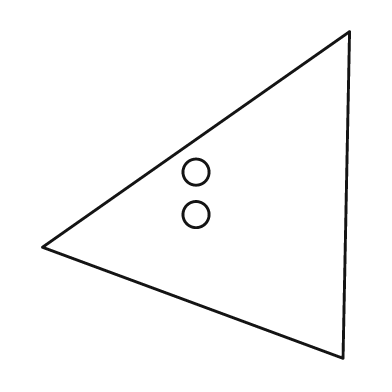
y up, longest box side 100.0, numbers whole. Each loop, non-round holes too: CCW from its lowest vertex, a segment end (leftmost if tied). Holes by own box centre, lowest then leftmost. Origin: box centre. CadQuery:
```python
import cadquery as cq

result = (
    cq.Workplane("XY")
    .moveTo(45.0, -50.0)
    .lineTo(47.0, 50.0)
    .lineTo(-47.0, -16.0)
    .close()
    .moveTo(0.0, -6.0)
    .circle(4.0)
    .moveTo(0.0, 7.0)
    .circle(4.0)
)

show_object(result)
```